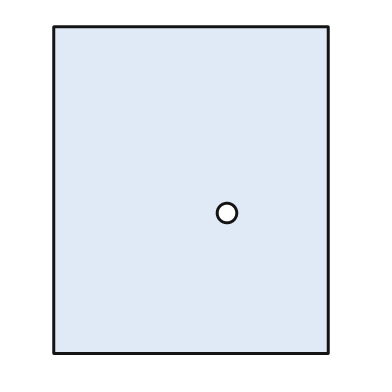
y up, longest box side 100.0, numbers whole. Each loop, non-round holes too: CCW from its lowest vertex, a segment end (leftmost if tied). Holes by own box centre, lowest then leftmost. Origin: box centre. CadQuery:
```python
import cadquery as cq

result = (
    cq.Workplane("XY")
    .moveTo(-42.0, -50.0)
    .lineTo(42.0, -50.0)
    .lineTo(42.0, 50.0)
    .lineTo(-42.0, 50.0)
    .close()
    .moveTo(11.0, -7.0)
    .circle(3.0)
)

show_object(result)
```